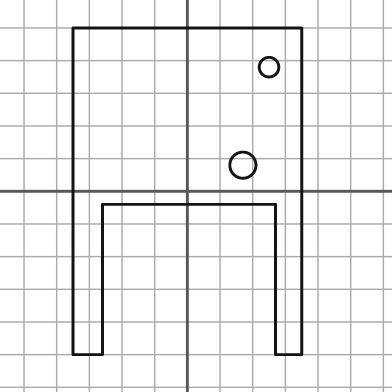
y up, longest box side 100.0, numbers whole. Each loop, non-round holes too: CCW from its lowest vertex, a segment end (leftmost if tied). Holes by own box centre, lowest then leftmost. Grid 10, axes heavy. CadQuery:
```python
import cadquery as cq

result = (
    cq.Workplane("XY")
    .moveTo(-35.0, -50.0)
    .lineTo(-26.0, -50.0)
    .lineTo(-26.0, -4.0)
    .lineTo(27.0, -4.0)
    .lineTo(27.0, -50.0)
    .lineTo(35.0, -50.0)
    .lineTo(35.0, 50.0)
    .lineTo(-35.0, 50.0)
    .close()
    .moveTo(17.0, 8.0)
    .circle(4.0)
    .moveTo(25.0, 38.0)
    .circle(3.0)
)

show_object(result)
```